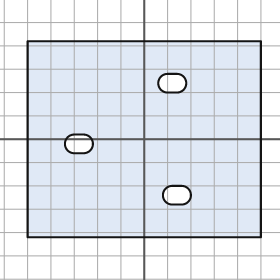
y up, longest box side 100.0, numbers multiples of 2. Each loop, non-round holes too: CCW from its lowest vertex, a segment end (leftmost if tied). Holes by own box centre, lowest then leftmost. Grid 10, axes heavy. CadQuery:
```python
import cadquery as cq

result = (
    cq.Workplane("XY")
    .moveTo(-50.0, -42.0)
    .lineTo(50.0, -42.0)
    .lineTo(50.0, 42.0)
    .lineTo(-50.0, 42.0)
    .close()
    .moveTo(12.0, -28.0)
    .lineTo(16.0, -28.0)
    .threePointArc((20.0, -24.0), (16.0, -20.0))
    .lineTo(12.0, -20.0)
    .threePointArc((8.0, -24.0), (12.0, -28.0))
    .close()
    .moveTo(-30.0, -6.0)
    .lineTo(-26.0, -6.0)
    .threePointArc((-22.0, -2.0), (-26.0, 2.0))
    .lineTo(-30.0, 2.0)
    .threePointArc((-34.0, -2.0), (-30.0, -6.0))
    .close()
    .moveTo(10.0, 20.0)
    .lineTo(14.0, 20.0)
    .threePointArc((18.0, 24.0), (14.0, 28.0))
    .lineTo(10.0, 28.0)
    .threePointArc((6.0, 24.0), (10.0, 20.0))
    .close()
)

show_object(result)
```